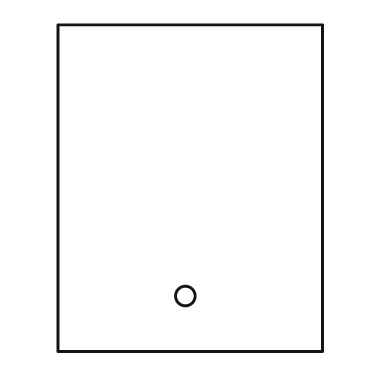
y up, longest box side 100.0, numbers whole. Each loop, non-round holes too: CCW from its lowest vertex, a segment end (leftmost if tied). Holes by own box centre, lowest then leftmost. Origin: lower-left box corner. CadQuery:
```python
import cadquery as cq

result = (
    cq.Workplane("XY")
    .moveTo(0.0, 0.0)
    .lineTo(81.0, 0.0)
    .lineTo(81.0, 100.0)
    .lineTo(0.0, 100.0)
    .close()
    .moveTo(39.0, 17.0)
    .circle(3.0)
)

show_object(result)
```